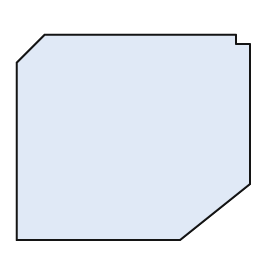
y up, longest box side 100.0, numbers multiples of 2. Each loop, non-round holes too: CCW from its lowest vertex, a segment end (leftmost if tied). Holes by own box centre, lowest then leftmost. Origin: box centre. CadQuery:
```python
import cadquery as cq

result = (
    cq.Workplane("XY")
    .moveTo(-50.0, -44.0)
    .lineTo(20.0, -44.0)
    .lineTo(50.0, -20.0)
    .lineTo(50.0, 40.0)
    .lineTo(44.0, 40.0)
    .lineTo(44.0, 44.0)
    .lineTo(-38.0, 44.0)
    .lineTo(-50.0, 32.0)
    .close()
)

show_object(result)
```